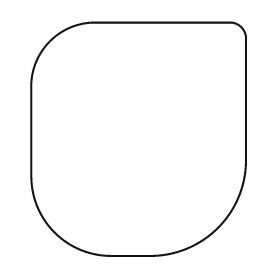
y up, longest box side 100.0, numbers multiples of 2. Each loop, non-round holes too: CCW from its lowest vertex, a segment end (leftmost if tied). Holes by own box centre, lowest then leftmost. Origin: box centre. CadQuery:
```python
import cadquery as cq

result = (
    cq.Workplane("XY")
    .moveTo(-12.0, -50.0)
    .lineTo(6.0, -50.0)
    .threePointArc((34.0, -38.0), (46.0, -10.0))
    .lineTo(46.0, 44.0)
    .threePointArc((44.0, 48.0), (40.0, 50.0))
    .lineTo(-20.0, 50.0)
    .threePointArc((-38.0, 42.0), (-46.0, 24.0))
    .lineTo(-46.0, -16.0)
    .threePointArc((-36.0, -40.0), (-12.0, -50.0))
    .close()
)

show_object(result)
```